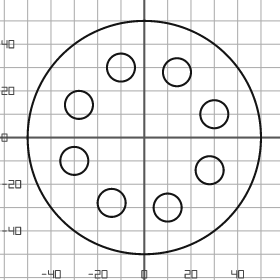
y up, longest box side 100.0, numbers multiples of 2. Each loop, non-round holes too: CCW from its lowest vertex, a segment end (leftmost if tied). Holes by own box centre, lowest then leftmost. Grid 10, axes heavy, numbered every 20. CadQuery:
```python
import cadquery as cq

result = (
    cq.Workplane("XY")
    .moveTo(0.0, 0.0)
    .circle(50.0)
    .moveTo(10.0, -30.0)
    .circle(6.0)
    .moveTo(-14.0, -28.0)
    .circle(6.0)
    .moveTo(28.0, -14.0)
    .circle(6.0)
    .moveTo(-30.0, -10.0)
    .circle(6.0)
    .moveTo(30.0, 10.0)
    .circle(6.0)
    .moveTo(-28.0, 14.0)
    .circle(6.0)
    .moveTo(14.0, 28.0)
    .circle(6.0)
    .moveTo(-10.0, 30.0)
    .circle(6.0)
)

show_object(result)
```